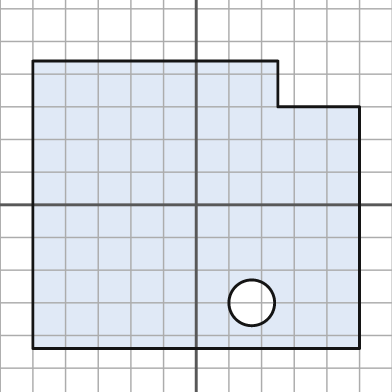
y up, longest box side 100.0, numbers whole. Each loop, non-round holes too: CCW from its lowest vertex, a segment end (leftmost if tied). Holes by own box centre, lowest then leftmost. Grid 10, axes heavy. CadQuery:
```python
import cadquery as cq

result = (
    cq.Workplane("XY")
    .moveTo(-50.0, -44.0)
    .lineTo(50.0, -44.0)
    .lineTo(50.0, 30.0)
    .lineTo(25.0, 30.0)
    .lineTo(25.0, 44.0)
    .lineTo(-50.0, 44.0)
    .close()
    .moveTo(17.0, -30.0)
    .circle(7.0)
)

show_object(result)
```